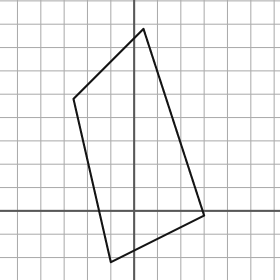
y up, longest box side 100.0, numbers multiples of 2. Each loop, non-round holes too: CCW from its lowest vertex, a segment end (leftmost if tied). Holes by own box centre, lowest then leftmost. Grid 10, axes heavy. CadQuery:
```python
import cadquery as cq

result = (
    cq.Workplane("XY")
    .moveTo(-10.0, -22.0)
    .lineTo(30.0, -2.0)
    .lineTo(4.0, 78.0)
    .lineTo(-26.0, 48.0)
    .close()
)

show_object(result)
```